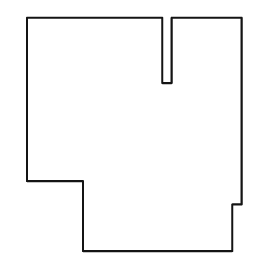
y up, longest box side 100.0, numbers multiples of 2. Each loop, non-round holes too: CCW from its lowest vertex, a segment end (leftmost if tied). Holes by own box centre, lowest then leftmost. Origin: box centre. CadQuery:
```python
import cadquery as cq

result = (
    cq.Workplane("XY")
    .moveTo(-22.0, -50.0)
    .lineTo(42.0, -50.0)
    .lineTo(42.0, -30.0)
    .lineTo(46.0, -30.0)
    .lineTo(46.0, 50.0)
    .lineTo(16.0, 50.0)
    .lineTo(16.0, 22.0)
    .lineTo(12.0, 22.0)
    .lineTo(12.0, 50.0)
    .lineTo(-46.0, 50.0)
    .lineTo(-46.0, -20.0)
    .lineTo(-22.0, -20.0)
    .close()
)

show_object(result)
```